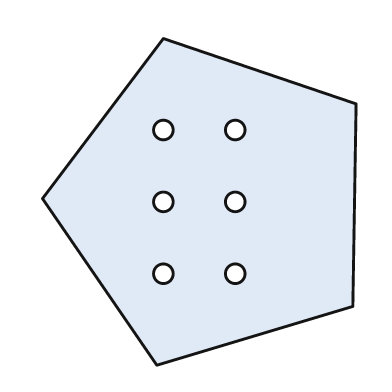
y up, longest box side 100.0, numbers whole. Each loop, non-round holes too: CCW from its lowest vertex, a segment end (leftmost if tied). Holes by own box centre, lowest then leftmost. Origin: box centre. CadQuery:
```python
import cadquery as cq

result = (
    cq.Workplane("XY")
    .moveTo(-13.0, -50.0)
    .lineTo(47.0, -32.0)
    .lineTo(48.0, 30.0)
    .lineTo(-11.0, 50.0)
    .lineTo(-48.0, 1.0)
    .close()
    .moveTo(-11.0, -22.0)
    .circle(3.0)
    .moveTo(11.0, -22.0)
    .circle(3.0)
    .moveTo(-11.0, 0.0)
    .circle(3.0)
    .moveTo(11.0, 0.0)
    .circle(3.0)
    .moveTo(-11.0, 22.0)
    .circle(3.0)
    .moveTo(11.0, 22.0)
    .circle(3.0)
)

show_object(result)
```